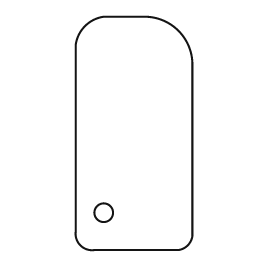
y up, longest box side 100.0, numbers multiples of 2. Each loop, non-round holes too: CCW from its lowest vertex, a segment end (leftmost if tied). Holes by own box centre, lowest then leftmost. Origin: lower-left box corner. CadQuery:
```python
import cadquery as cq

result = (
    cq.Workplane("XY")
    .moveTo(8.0, 0.0)
    .lineTo(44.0, 0.0)
    .threePointArc((48.0, 2.0), (50.0, 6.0))
    .lineTo(50.0, 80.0)
    .threePointArc((44.0, 94.0), (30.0, 100.0))
    .lineTo(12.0, 100.0)
    .threePointArc((4.0, 96.0), (0.0, 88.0))
    .lineTo(0.0, 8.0)
    .threePointArc((2.0, 2.0), (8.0, 0.0))
    .close()
    .moveTo(12.0, 16.0)
    .circle(4.0)
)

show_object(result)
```